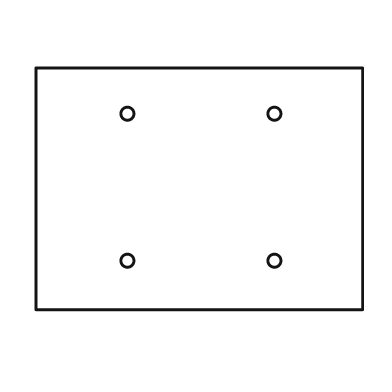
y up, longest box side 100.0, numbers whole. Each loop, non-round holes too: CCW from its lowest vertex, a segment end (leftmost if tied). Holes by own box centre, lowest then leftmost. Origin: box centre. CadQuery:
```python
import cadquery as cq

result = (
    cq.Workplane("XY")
    .moveTo(-50.0, -37.0)
    .lineTo(50.0, -37.0)
    .lineTo(50.0, 37.0)
    .lineTo(-50.0, 37.0)
    .close()
    .moveTo(-22.0, -22.0)
    .circle(2.0)
    .moveTo(23.0, -22.0)
    .circle(2.0)
    .moveTo(-22.0, 23.0)
    .circle(2.0)
    .moveTo(23.0, 23.0)
    .circle(2.0)
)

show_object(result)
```